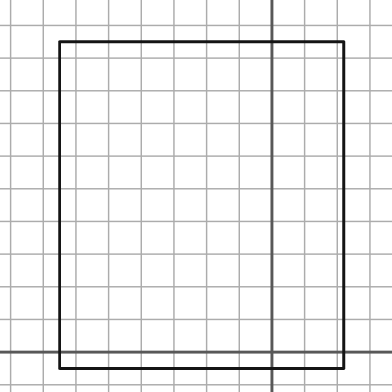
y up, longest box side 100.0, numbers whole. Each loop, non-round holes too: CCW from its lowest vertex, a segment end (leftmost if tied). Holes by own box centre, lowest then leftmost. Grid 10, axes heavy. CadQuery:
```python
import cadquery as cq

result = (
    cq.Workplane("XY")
    .moveTo(-65.0, -5.0)
    .lineTo(22.0, -5.0)
    .lineTo(22.0, 95.0)
    .lineTo(-65.0, 95.0)
    .close()
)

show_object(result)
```